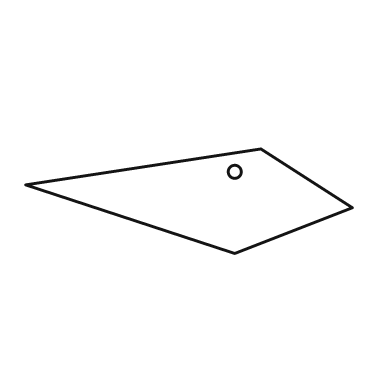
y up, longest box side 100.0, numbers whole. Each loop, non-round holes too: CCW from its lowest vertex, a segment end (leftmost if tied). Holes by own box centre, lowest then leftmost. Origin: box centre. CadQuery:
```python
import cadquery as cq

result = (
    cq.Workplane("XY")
    .moveTo(14.0, -16.0)
    .lineTo(50.0, -2.0)
    .lineTo(22.0, 16.0)
    .lineTo(-50.0, 5.0)
    .close()
    .moveTo(14.0, 9.0)
    .circle(2.0)
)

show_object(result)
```